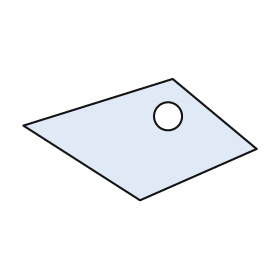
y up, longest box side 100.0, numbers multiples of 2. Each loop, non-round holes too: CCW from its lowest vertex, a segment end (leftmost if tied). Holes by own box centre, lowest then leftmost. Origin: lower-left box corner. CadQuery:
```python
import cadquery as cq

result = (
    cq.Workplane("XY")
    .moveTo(50.0, 0.0)
    .lineTo(100.0, 22.0)
    .lineTo(64.0, 52.0)
    .lineTo(0.0, 32.0)
    .close()
    .moveTo(62.0, 36.0)
    .circle(6.0)
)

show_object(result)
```